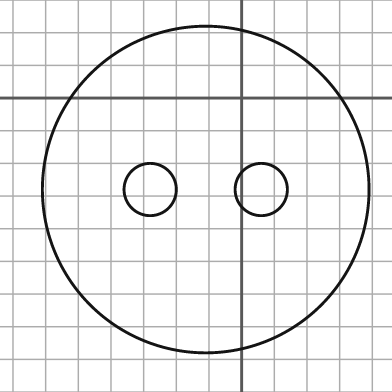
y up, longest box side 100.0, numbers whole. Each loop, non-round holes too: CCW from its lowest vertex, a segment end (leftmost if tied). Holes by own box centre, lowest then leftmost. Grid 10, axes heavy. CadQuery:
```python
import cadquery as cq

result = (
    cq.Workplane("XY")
    .moveTo(-11.0, -28.0)
    .circle(50.0)
    .moveTo(-28.0, -28.0)
    .circle(8.0)
    .moveTo(6.0, -28.0)
    .circle(8.0)
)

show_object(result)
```